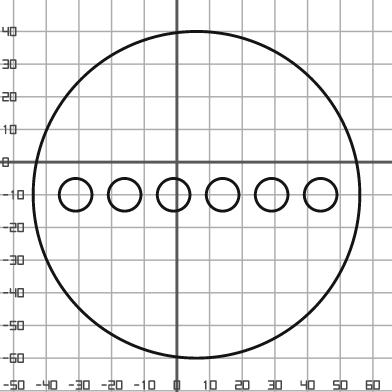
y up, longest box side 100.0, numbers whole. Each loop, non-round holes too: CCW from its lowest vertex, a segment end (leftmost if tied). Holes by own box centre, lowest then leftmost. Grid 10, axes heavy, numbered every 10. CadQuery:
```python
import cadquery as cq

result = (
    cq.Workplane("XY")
    .moveTo(6.0, -10.0)
    .circle(50.0)
    .moveTo(-31.0, -10.0)
    .circle(5.0)
    .moveTo(-16.0, -10.0)
    .circle(5.0)
    .moveTo(-1.0, -10.0)
    .circle(5.0)
    .moveTo(14.0, -10.0)
    .circle(5.0)
    .moveTo(29.0, -10.0)
    .circle(5.0)
    .moveTo(44.0, -10.0)
    .circle(5.0)
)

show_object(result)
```